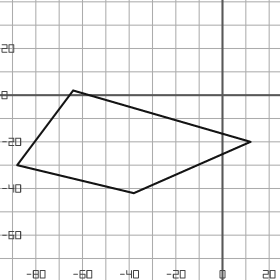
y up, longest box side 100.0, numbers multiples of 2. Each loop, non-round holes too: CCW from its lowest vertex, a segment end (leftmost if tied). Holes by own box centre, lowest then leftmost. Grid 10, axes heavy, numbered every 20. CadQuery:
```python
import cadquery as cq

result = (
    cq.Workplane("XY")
    .moveTo(-38.0, -42.0)
    .lineTo(12.0, -20.0)
    .lineTo(-64.0, 2.0)
    .lineTo(-88.0, -30.0)
    .close()
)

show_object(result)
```